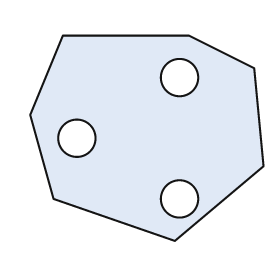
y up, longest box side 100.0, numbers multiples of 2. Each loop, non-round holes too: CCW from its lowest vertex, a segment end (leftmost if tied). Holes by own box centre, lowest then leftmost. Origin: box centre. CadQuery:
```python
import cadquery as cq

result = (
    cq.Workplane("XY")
    .moveTo(12.0, -44.0)
    .lineTo(50.0, -12.0)
    .lineTo(46.0, 30.0)
    .lineTo(18.0, 44.0)
    .lineTo(-36.0, 44.0)
    .lineTo(-50.0, 10.0)
    .lineTo(-40.0, -26.0)
    .close()
    .moveTo(14.0, -26.0)
    .circle(8.0)
    .moveTo(-30.0, 0.0)
    .circle(8.0)
    .moveTo(14.0, 26.0)
    .circle(8.0)
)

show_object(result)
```